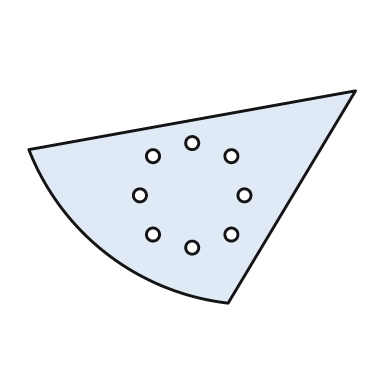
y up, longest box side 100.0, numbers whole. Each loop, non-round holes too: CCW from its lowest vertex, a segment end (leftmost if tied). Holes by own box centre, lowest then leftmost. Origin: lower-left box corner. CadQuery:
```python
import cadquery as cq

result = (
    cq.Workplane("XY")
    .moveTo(61.0, 0.0)
    .lineTo(100.0, 65.0)
    .lineTo(0.0, 47.0)
    .threePointArc((24.0, 15.0), (61.0, 0.0))
    .close()
    .moveTo(50.0, 17.0)
    .circle(2.0)
    .moveTo(38.0, 21.0)
    .circle(2.0)
    .moveTo(62.0, 21.0)
    .circle(2.0)
    .moveTo(34.0, 33.0)
    .circle(2.0)
    .moveTo(66.0, 33.0)
    .circle(2.0)
    .moveTo(38.0, 45.0)
    .circle(2.0)
    .moveTo(62.0, 45.0)
    .circle(2.0)
    .moveTo(50.0, 49.0)
    .circle(2.0)
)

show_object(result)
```